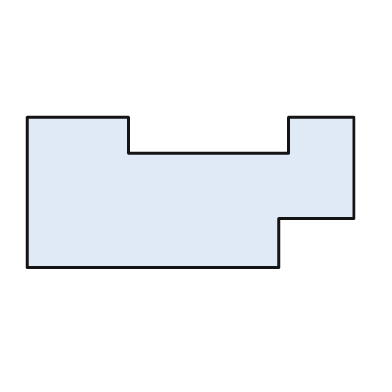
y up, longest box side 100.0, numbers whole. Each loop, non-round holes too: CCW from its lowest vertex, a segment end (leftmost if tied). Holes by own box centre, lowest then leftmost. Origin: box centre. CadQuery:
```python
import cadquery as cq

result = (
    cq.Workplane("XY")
    .moveTo(-50.0, -23.0)
    .lineTo(27.0, -23.0)
    .lineTo(27.0, -8.0)
    .lineTo(50.0, -8.0)
    .lineTo(50.0, 23.0)
    .lineTo(30.0, 23.0)
    .lineTo(30.0, 12.0)
    .lineTo(-19.0, 12.0)
    .lineTo(-19.0, 23.0)
    .lineTo(-50.0, 23.0)
    .close()
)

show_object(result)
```